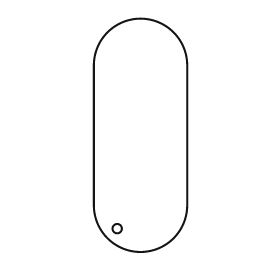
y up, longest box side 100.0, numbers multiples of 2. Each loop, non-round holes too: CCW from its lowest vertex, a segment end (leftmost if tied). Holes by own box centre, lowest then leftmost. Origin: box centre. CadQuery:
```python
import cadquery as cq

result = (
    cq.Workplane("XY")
    .moveTo(-20.0, -30.0)
    .threePointArc((0.0, -50.0), (20.0, -30.0))
    .lineTo(20.0, 30.0)
    .threePointArc((0.0, 50.0), (-20.0, 30.0))
    .close()
    .moveTo(-10.0, -40.0)
    .circle(2.0)
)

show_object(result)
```